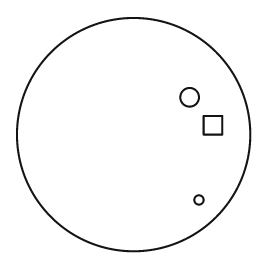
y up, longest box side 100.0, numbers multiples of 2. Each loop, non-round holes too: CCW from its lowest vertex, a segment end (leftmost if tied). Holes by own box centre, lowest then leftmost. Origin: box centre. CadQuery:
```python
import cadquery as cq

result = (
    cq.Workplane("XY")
    .moveTo(0.0, 0.0)
    .circle(50.0)
    .moveTo(28.0, -28.0)
    .circle(2.0)
    .moveTo(30.0, 0.0)
    .lineTo(38.0, 0.0)
    .lineTo(38.0, 8.0)
    .lineTo(30.0, 8.0)
    .close()
    .moveTo(24.0, 16.0)
    .circle(4.0)
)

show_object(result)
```